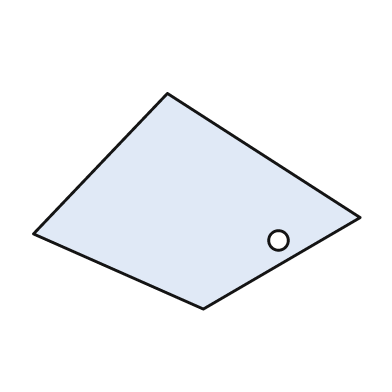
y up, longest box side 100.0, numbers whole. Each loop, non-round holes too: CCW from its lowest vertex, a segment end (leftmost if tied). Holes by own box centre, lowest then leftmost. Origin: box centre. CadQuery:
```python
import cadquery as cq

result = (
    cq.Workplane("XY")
    .moveTo(2.0, -33.0)
    .lineTo(50.0, -5.0)
    .lineTo(-9.0, 33.0)
    .lineTo(-50.0, -10.0)
    .close()
    .moveTo(25.0, -12.0)
    .circle(3.0)
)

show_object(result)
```